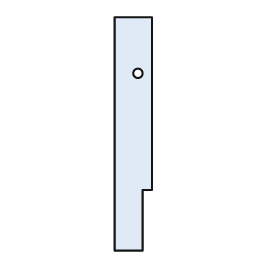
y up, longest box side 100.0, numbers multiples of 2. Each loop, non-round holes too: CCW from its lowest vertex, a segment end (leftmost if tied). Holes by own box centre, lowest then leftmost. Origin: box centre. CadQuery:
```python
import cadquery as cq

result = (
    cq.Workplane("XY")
    .moveTo(-8.0, -50.0)
    .lineTo(4.0, -50.0)
    .lineTo(4.0, -24.0)
    .lineTo(8.0, -24.0)
    .lineTo(8.0, 50.0)
    .lineTo(-8.0, 50.0)
    .close()
    .moveTo(2.0, 26.0)
    .circle(2.0)
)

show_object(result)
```